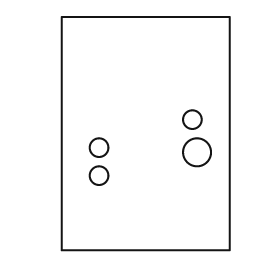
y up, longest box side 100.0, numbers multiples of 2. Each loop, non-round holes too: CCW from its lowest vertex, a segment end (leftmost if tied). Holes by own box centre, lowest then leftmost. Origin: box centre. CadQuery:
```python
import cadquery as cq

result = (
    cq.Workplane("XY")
    .moveTo(-36.0, -50.0)
    .lineTo(36.0, -50.0)
    .lineTo(36.0, 50.0)
    .lineTo(-36.0, 50.0)
    .close()
    .moveTo(-20.0, -18.0)
    .circle(4.0)
    .moveTo(22.0, -8.0)
    .circle(6.0)
    .moveTo(-20.0, -6.0)
    .circle(4.0)
    .moveTo(20.0, 6.0)
    .circle(4.0)
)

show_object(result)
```